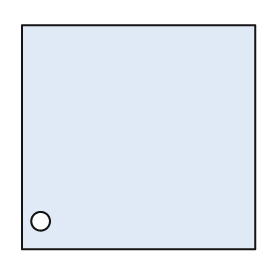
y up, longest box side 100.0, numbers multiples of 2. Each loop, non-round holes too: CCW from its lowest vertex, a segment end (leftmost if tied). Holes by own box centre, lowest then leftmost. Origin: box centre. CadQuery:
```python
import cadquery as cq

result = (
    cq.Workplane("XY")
    .moveTo(-50.0, -48.0)
    .lineTo(50.0, -48.0)
    .lineTo(50.0, 48.0)
    .lineTo(-50.0, 48.0)
    .close()
    .moveTo(-42.0, -36.0)
    .circle(4.0)
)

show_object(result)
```